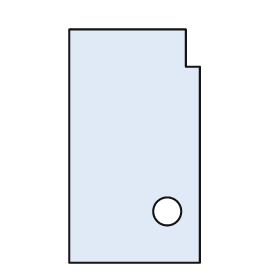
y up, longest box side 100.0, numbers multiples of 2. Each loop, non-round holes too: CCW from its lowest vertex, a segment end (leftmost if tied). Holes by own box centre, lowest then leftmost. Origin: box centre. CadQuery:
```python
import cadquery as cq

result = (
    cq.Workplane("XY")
    .moveTo(-28.0, -50.0)
    .lineTo(28.0, -50.0)
    .lineTo(28.0, 34.0)
    .lineTo(22.0, 34.0)
    .lineTo(22.0, 50.0)
    .lineTo(-28.0, 50.0)
    .close()
    .moveTo(14.0, -28.0)
    .circle(6.0)
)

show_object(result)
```